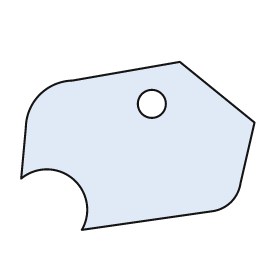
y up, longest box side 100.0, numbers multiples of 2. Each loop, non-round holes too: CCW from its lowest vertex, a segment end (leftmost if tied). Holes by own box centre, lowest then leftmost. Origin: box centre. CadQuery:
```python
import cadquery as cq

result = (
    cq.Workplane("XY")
    .moveTo(-24.0, -36.0)
    .lineTo(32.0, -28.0)
    .threePointArc((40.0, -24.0), (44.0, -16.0))
    .lineTo(50.0, 10.0)
    .lineTo(18.0, 36.0)
    .lineTo(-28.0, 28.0)
    .threePointArc((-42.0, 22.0), (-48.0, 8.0))
    .lineTo(-50.0, -14.0)
    .threePointArc((-28.0, -14.0), (-24.0, -36.0))
    .close()
    .moveTo(6.0, 18.0)
    .circle(6.0)
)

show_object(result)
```